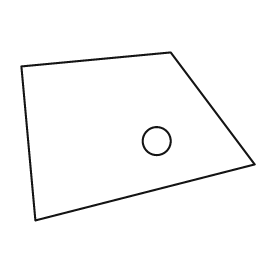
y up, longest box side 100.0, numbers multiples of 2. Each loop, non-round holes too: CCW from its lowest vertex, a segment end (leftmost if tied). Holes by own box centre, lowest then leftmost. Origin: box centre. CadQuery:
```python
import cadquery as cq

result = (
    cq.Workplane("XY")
    .moveTo(-44.0, -36.0)
    .lineTo(50.0, -12.0)
    .lineTo(14.0, 36.0)
    .lineTo(-50.0, 30.0)
    .close()
    .moveTo(8.0, -2.0)
    .circle(6.0)
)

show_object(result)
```